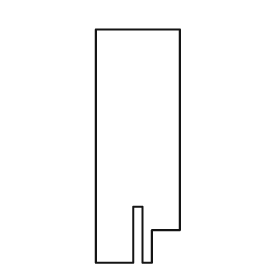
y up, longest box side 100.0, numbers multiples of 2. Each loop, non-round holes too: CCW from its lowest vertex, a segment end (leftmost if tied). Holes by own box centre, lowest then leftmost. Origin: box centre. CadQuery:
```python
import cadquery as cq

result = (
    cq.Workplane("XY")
    .moveTo(-18.0, -50.0)
    .lineTo(-2.0, -50.0)
    .lineTo(-2.0, -26.0)
    .lineTo(2.0, -26.0)
    .lineTo(2.0, -50.0)
    .lineTo(6.0, -50.0)
    .lineTo(6.0, -36.0)
    .lineTo(18.0, -36.0)
    .lineTo(18.0, 50.0)
    .lineTo(-18.0, 50.0)
    .close()
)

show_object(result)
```